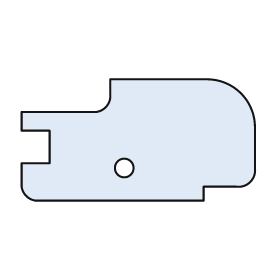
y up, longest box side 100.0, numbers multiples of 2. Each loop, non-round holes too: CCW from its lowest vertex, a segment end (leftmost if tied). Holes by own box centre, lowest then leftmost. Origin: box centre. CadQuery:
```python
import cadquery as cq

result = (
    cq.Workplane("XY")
    .moveTo(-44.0, -26.0)
    .lineTo(28.0, -26.0)
    .lineTo(28.0, -20.0)
    .lineTo(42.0, -20.0)
    .threePointArc((48.0, -18.0), (50.0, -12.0))
    .lineTo(50.0, 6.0)
    .threePointArc((44.0, 20.0), (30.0, 26.0))
    .lineTo(-12.0, 26.0)
    .lineTo(-12.0, 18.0)
    .threePointArc((-14.0, 14.0), (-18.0, 12.0))
    .lineTo(-50.0, 12.0)
    .lineTo(-50.0, 4.0)
    .lineTo(-38.0, 4.0)
    .lineTo(-38.0, -10.0)
    .lineTo(-50.0, -10.0)
    .lineTo(-50.0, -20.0)
    .threePointArc((-48.0, -24.0), (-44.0, -26.0))
    .close()
    .moveTo(-6.0, -12.0)
    .circle(4.0)
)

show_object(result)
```